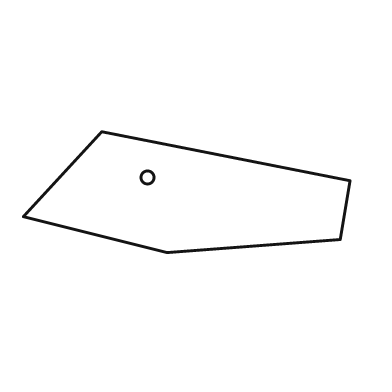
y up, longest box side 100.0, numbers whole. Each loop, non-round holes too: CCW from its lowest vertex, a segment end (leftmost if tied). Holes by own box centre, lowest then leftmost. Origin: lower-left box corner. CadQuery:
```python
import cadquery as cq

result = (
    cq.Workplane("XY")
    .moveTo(44.0, 0.0)
    .lineTo(97.0, 4.0)
    .lineTo(100.0, 22.0)
    .lineTo(24.0, 37.0)
    .lineTo(0.0, 11.0)
    .close()
    .moveTo(38.0, 23.0)
    .circle(2.0)
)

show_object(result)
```